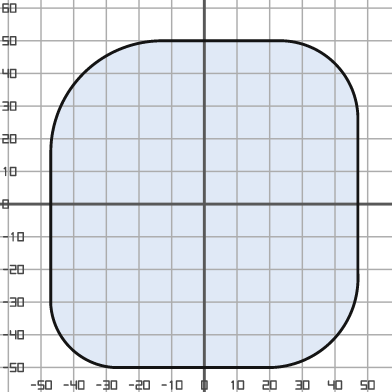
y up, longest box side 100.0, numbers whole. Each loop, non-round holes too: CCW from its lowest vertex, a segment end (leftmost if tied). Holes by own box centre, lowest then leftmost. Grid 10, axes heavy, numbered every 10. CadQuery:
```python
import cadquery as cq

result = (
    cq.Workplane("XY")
    .moveTo(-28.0, -50.0)
    .lineTo(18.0, -50.0)
    .threePointArc((39.0, -42.0), (47.0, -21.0))
    .lineTo(47.0, 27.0)
    .threePointArc((40.0, 43.0), (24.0, 50.0))
    .lineTo(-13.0, 50.0)
    .threePointArc((-37.0, 40.0), (-47.0, 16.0))
    .lineTo(-47.0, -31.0)
    .threePointArc((-41.0, -44.0), (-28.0, -50.0))
    .close()
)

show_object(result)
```